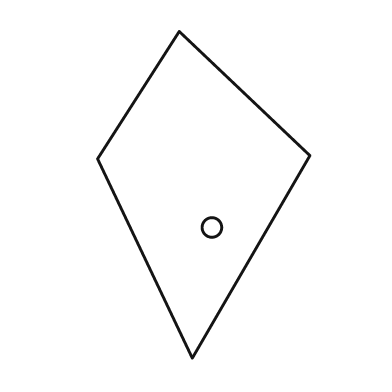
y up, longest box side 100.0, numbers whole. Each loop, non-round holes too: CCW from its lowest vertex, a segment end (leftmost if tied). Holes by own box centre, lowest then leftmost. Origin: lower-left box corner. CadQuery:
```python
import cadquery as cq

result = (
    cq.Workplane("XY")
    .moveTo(29.0, 0.0)
    .lineTo(65.0, 62.0)
    .lineTo(25.0, 100.0)
    .lineTo(0.0, 61.0)
    .close()
    .moveTo(35.0, 40.0)
    .circle(3.0)
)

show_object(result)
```